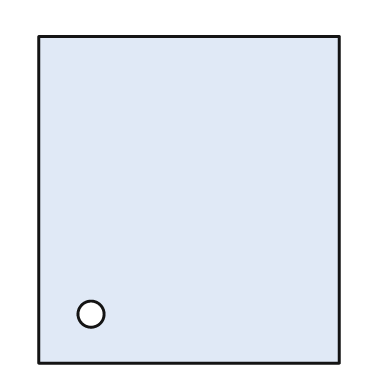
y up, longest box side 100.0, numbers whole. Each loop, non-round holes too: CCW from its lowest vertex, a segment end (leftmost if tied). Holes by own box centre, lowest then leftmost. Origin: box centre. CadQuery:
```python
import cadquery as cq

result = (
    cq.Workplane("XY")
    .moveTo(-46.0, -50.0)
    .lineTo(46.0, -50.0)
    .lineTo(46.0, 50.0)
    .lineTo(-46.0, 50.0)
    .close()
    .moveTo(-30.0, -35.0)
    .circle(4.0)
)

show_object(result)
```